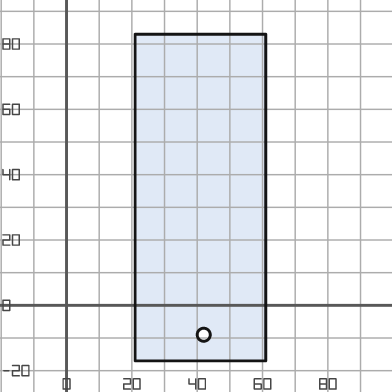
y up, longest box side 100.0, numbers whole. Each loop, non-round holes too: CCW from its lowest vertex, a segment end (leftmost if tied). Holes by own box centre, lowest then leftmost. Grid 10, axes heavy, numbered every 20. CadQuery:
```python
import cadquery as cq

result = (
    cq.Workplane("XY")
    .moveTo(21.0, -17.0)
    .lineTo(61.0, -17.0)
    .lineTo(61.0, 83.0)
    .lineTo(21.0, 83.0)
    .close()
    .moveTo(42.0, -9.0)
    .circle(2.0)
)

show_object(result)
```